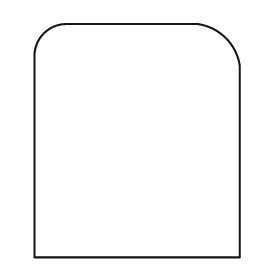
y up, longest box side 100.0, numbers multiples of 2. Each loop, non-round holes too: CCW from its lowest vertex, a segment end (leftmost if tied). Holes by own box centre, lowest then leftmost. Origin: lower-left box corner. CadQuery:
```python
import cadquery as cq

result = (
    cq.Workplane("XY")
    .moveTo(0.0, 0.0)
    .lineTo(88.0, 0.0)
    .lineTo(88.0, 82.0)
    .threePointArc((82.0, 94.0), (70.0, 100.0))
    .lineTo(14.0, 100.0)
    .threePointArc((4.0, 96.0), (0.0, 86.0))
    .close()
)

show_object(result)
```